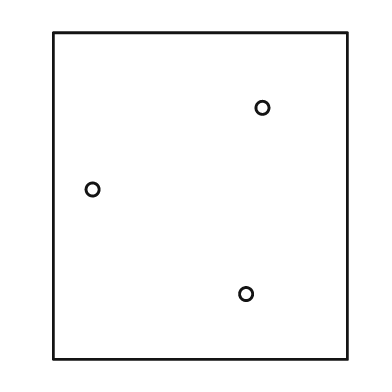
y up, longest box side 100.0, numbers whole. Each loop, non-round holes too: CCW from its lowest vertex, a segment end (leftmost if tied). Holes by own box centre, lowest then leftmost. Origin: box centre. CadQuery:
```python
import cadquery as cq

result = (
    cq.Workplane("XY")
    .moveTo(-45.0, -50.0)
    .lineTo(45.0, -50.0)
    .lineTo(45.0, 50.0)
    .lineTo(-45.0, 50.0)
    .close()
    .moveTo(14.0, -30.0)
    .circle(2.0)
    .moveTo(-33.0, 2.0)
    .circle(2.0)
    .moveTo(19.0, 27.0)
    .circle(2.0)
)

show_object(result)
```